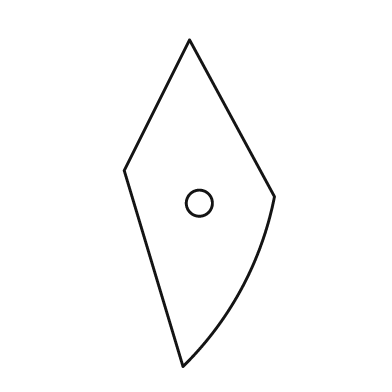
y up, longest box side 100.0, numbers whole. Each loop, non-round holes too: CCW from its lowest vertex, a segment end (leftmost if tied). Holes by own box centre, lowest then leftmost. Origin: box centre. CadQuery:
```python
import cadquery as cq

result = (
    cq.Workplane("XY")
    .moveTo(-5.0, -50.0)
    .threePointArc((13.0, -26.0), (23.0, 2.0))
    .lineTo(-3.0, 50.0)
    .lineTo(-23.0, 10.0)
    .close()
    .moveTo(0.0, 0.0)
    .circle(4.0)
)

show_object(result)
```